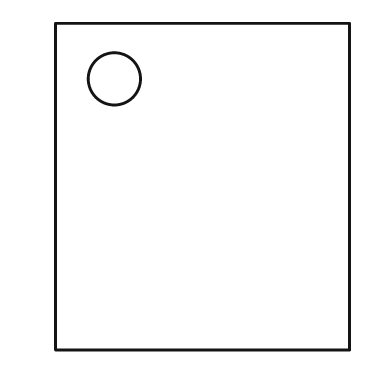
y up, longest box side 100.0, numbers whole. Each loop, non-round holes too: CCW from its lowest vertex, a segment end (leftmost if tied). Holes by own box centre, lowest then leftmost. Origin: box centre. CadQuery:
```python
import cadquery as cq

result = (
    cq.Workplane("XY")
    .moveTo(-45.0, -50.0)
    .lineTo(45.0, -50.0)
    .lineTo(45.0, 50.0)
    .lineTo(-45.0, 50.0)
    .close()
    .moveTo(-27.0, 33.0)
    .circle(8.0)
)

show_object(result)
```